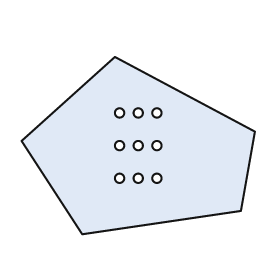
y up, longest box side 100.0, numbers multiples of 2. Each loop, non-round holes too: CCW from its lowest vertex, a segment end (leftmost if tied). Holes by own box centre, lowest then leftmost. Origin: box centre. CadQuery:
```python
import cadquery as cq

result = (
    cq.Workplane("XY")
    .moveTo(-24.0, -38.0)
    .lineTo(44.0, -28.0)
    .lineTo(50.0, 6.0)
    .lineTo(-10.0, 38.0)
    .lineTo(-50.0, 2.0)
    .close()
    .moveTo(-8.0, -14.0)
    .circle(2.0)
    .moveTo(0.0, -14.0)
    .circle(2.0)
    .moveTo(8.0, -14.0)
    .circle(2.0)
    .moveTo(-8.0, 0.0)
    .circle(2.0)
    .moveTo(0.0, 0.0)
    .circle(2.0)
    .moveTo(8.0, 0.0)
    .circle(2.0)
    .moveTo(-8.0, 14.0)
    .circle(2.0)
    .moveTo(0.0, 14.0)
    .circle(2.0)
    .moveTo(8.0, 14.0)
    .circle(2.0)
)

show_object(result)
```